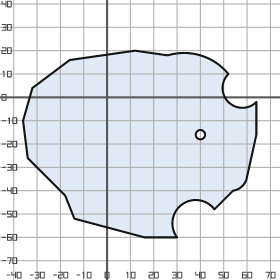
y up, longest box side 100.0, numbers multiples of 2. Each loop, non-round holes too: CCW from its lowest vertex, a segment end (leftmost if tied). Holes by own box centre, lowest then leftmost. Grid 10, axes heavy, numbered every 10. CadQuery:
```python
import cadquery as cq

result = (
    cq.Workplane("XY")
    .moveTo(16.0, -60.0)
    .lineTo(30.0, -60.0)
    .threePointArc((32.0, -46.0), (46.0, -48.0))
    .lineTo(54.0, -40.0)
    .threePointArc((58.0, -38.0), (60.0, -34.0))
    .lineTo(64.0, -16.0)
    .lineTo(64.0, -2.0)
    .threePointArc((52.0, -2.0), (52.0, 10.0))
    .threePointArc((40.0, 18.0), (26.0, 18.0))
    .lineTo(12.0, 20.0)
    .lineTo(-16.0, 16.0)
    .lineTo(-32.0, 4.0)
    .lineTo(-36.0, -10.0)
    .lineTo(-34.0, -26.0)
    .lineTo(-18.0, -42.0)
    .lineTo(-14.0, -52.0)
    .close()
    .moveTo(40.0, -16.0)
    .circle(2.0)
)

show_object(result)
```